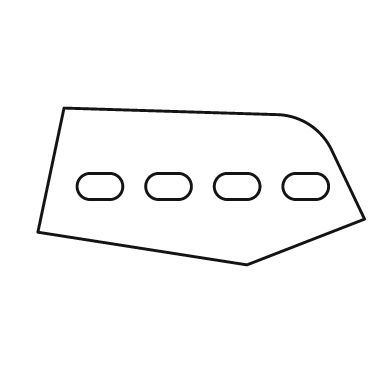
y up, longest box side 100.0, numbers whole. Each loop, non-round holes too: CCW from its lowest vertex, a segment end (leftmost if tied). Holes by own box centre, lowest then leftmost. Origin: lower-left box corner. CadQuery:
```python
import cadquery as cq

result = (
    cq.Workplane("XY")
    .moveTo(64.0, 0.0)
    .lineTo(100.0, 14.0)
    .lineTo(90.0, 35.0)
    .threePointArc((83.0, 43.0), (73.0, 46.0))
    .lineTo(8.0, 48.0)
    .lineTo(0.0, 10.0)
    .close()
    .moveTo(16.0, 20.0)
    .lineTo(22.0, 20.0)
    .threePointArc((26.0, 24.0), (22.0, 28.0))
    .lineTo(16.0, 28.0)
    .threePointArc((12.0, 24.0), (16.0, 20.0))
    .close()
    .moveTo(37.0, 20.0)
    .lineTo(43.0, 20.0)
    .threePointArc((47.0, 24.0), (43.0, 28.0))
    .lineTo(37.0, 28.0)
    .threePointArc((33.0, 24.0), (37.0, 20.0))
    .close()
    .moveTo(58.0, 20.0)
    .lineTo(64.0, 20.0)
    .threePointArc((68.0, 24.0), (64.0, 28.0))
    .lineTo(58.0, 28.0)
    .threePointArc((54.0, 24.0), (58.0, 20.0))
    .close()
    .moveTo(79.0, 20.0)
    .lineTo(85.0, 20.0)
    .threePointArc((89.0, 24.0), (85.0, 28.0))
    .lineTo(79.0, 28.0)
    .threePointArc((75.0, 24.0), (79.0, 20.0))
    .close()
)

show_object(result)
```